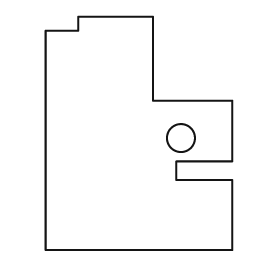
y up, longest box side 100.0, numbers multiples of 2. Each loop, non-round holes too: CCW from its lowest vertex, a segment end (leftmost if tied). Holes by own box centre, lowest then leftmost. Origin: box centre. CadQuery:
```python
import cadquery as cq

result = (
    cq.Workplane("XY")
    .moveTo(-40.0, -50.0)
    .lineTo(40.0, -50.0)
    .lineTo(40.0, -20.0)
    .lineTo(16.0, -20.0)
    .lineTo(16.0, -12.0)
    .lineTo(40.0, -12.0)
    .lineTo(40.0, 14.0)
    .lineTo(6.0, 14.0)
    .lineTo(6.0, 50.0)
    .lineTo(-26.0, 50.0)
    .lineTo(-26.0, 44.0)
    .lineTo(-40.0, 44.0)
    .close()
    .moveTo(18.0, -2.0)
    .circle(6.0)
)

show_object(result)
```